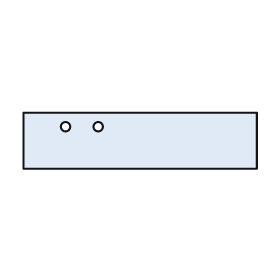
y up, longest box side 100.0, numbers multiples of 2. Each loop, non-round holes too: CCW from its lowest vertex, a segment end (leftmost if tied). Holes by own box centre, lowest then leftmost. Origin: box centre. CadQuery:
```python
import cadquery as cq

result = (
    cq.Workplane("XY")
    .moveTo(-50.0, -12.0)
    .lineTo(50.0, -12.0)
    .lineTo(50.0, 12.0)
    .lineTo(-50.0, 12.0)
    .close()
    .moveTo(-32.0, 6.0)
    .circle(2.0)
    .moveTo(-18.0, 6.0)
    .circle(2.0)
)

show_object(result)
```